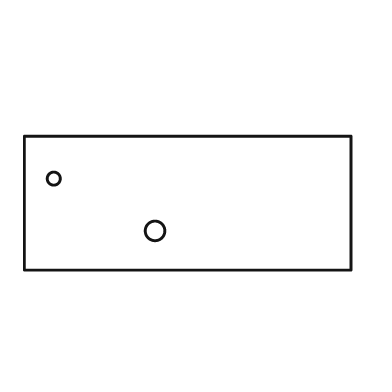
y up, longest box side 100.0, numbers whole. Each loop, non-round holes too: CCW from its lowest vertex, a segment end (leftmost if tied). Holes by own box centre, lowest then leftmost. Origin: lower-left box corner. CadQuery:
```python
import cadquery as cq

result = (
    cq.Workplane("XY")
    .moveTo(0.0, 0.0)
    .lineTo(100.0, 0.0)
    .lineTo(100.0, 41.0)
    .lineTo(0.0, 41.0)
    .close()
    .moveTo(40.0, 12.0)
    .circle(3.0)
    .moveTo(9.0, 28.0)
    .circle(2.0)
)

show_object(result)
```